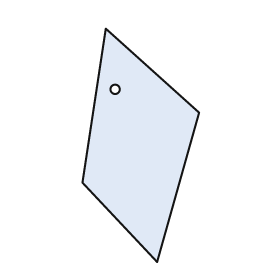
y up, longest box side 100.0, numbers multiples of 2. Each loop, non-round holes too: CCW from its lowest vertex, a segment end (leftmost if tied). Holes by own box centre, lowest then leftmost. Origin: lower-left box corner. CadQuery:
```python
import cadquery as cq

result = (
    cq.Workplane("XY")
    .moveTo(32.0, 0.0)
    .lineTo(50.0, 64.0)
    .lineTo(10.0, 100.0)
    .lineTo(0.0, 34.0)
    .close()
    .moveTo(14.0, 74.0)
    .circle(2.0)
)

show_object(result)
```